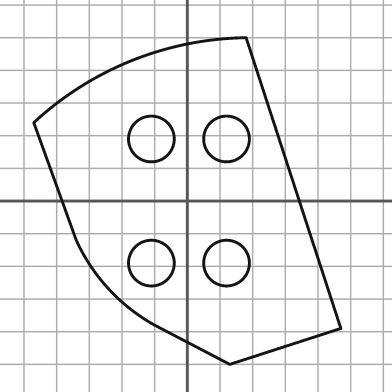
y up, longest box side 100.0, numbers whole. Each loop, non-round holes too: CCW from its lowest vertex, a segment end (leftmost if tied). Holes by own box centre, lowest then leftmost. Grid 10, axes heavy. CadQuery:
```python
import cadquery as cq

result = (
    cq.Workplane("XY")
    .moveTo(13.0, -50.0)
    .lineTo(47.0, -39.0)
    .lineTo(18.0, 50.0)
    .threePointArc((-17.0, 43.0), (-47.0, 24.0))
    .lineTo(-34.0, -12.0)
    .threePointArc((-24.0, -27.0), (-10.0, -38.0))
    .close()
    .moveTo(-11.0, -19.0)
    .circle(7.0)
    .moveTo(12.0, -19.0)
    .circle(7.0)
    .moveTo(-11.0, 19.0)
    .circle(7.0)
    .moveTo(12.0, 19.0)
    .circle(7.0)
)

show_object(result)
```